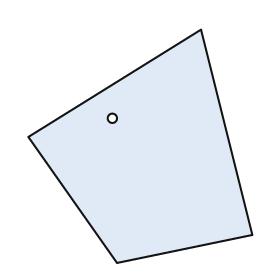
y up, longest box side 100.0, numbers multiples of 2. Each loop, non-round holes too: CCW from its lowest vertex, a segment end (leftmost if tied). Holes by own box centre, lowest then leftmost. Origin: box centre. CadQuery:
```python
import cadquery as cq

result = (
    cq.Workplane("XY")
    .moveTo(-10.0, -50.0)
    .lineTo(48.0, -38.0)
    .lineTo(26.0, 50.0)
    .lineTo(-48.0, 4.0)
    .close()
    .moveTo(-12.0, 12.0)
    .circle(2.0)
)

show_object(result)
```